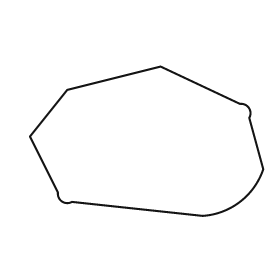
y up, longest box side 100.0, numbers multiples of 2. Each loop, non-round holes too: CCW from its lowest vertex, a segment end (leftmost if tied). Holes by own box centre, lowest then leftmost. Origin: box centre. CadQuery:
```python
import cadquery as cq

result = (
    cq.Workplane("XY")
    .moveTo(24.0, -32.0)
    .threePointArc((40.0, -26.0), (50.0, -12.0))
    .lineTo(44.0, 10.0)
    .threePointArc((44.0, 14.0), (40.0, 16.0))
    .lineTo(6.0, 32.0)
    .lineTo(-34.0, 22.0)
    .lineTo(-50.0, 2.0)
    .lineTo(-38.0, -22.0)
    .threePointArc((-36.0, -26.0), (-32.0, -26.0))
    .close()
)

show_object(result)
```